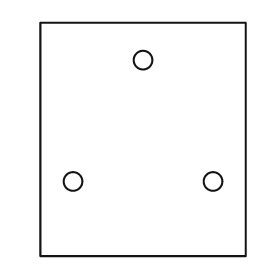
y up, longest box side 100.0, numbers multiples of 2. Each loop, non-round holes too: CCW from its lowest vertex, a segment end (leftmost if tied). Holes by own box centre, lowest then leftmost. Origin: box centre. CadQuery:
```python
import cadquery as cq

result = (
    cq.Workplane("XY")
    .moveTo(-44.0, -50.0)
    .lineTo(44.0, -50.0)
    .lineTo(44.0, 50.0)
    .lineTo(-44.0, 50.0)
    .close()
    .moveTo(-30.0, -18.0)
    .circle(4.0)
    .moveTo(30.0, -18.0)
    .circle(4.0)
    .moveTo(0.0, 34.0)
    .circle(4.0)
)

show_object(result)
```